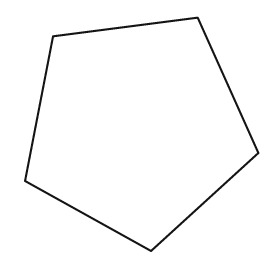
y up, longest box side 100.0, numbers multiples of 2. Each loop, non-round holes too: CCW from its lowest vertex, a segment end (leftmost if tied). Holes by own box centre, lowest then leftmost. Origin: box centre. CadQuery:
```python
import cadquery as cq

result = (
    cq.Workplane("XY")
    .moveTo(4.0, -50.0)
    .lineTo(50.0, -8.0)
    .lineTo(24.0, 50.0)
    .lineTo(-38.0, 42.0)
    .lineTo(-50.0, -20.0)
    .close()
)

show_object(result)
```